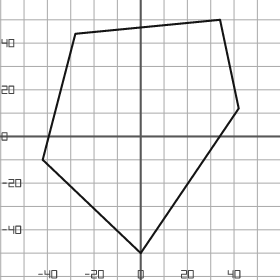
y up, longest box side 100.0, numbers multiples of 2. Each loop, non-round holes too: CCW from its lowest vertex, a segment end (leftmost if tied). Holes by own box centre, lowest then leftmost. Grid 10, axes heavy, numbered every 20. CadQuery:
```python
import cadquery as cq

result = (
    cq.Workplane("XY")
    .moveTo(0.0, -50.0)
    .lineTo(42.0, 12.0)
    .lineTo(34.0, 50.0)
    .lineTo(-28.0, 44.0)
    .lineTo(-42.0, -10.0)
    .close()
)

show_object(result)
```